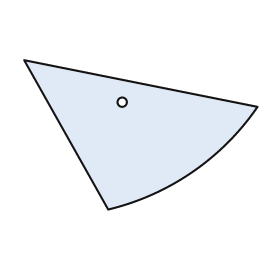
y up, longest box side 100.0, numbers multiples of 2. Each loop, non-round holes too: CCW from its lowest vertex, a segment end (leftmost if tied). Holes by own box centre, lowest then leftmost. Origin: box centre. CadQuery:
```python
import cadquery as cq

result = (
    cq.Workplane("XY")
    .moveTo(-14.0, -32.0)
    .threePointArc((22.0, -16.0), (50.0, 12.0))
    .lineTo(-50.0, 32.0)
    .close()
    .moveTo(-8.0, 14.0)
    .circle(2.0)
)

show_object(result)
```